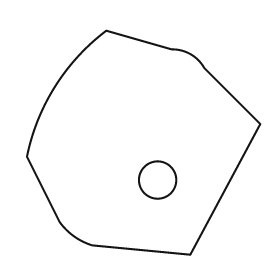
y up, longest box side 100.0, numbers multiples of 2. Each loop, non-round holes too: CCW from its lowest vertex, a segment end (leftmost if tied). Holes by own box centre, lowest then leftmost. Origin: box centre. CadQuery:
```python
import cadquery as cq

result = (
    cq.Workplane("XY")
    .moveTo(20.0, -48.0)
    .lineTo(50.0, 8.0)
    .lineTo(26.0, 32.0)
    .threePointArc((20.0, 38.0), (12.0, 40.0))
    .lineTo(-16.0, 48.0)
    .threePointArc((-38.0, 24.0), (-50.0, -6.0))
    .lineTo(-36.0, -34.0)
    .threePointArc((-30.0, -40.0), (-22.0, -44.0))
    .close()
    .moveTo(6.0, -16.0)
    .circle(8.0)
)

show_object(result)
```